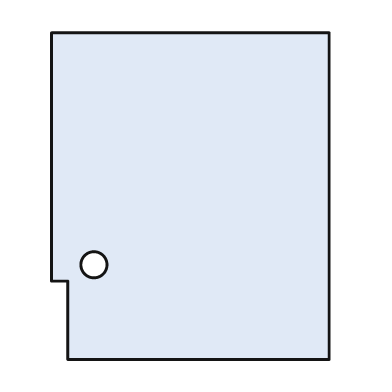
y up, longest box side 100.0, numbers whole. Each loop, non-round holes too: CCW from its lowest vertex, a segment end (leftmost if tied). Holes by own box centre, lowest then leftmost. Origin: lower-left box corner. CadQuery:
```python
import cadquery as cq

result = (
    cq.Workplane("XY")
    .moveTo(5.0, 0.0)
    .lineTo(85.0, 0.0)
    .lineTo(85.0, 100.0)
    .lineTo(0.0, 100.0)
    .lineTo(0.0, 24.0)
    .lineTo(5.0, 24.0)
    .close()
    .moveTo(13.0, 29.0)
    .circle(4.0)
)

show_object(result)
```